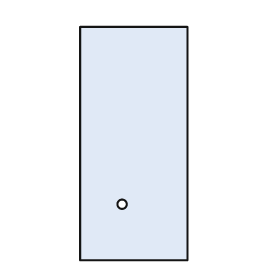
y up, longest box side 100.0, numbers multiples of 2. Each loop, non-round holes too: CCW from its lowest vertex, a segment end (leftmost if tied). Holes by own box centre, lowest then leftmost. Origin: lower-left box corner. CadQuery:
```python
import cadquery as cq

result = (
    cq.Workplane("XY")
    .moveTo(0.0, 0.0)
    .lineTo(46.0, 0.0)
    .lineTo(46.0, 100.0)
    .lineTo(0.0, 100.0)
    .close()
    .moveTo(18.0, 24.0)
    .circle(2.0)
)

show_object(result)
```